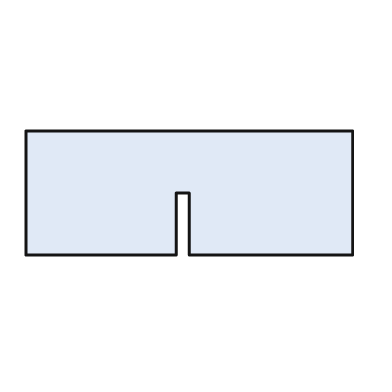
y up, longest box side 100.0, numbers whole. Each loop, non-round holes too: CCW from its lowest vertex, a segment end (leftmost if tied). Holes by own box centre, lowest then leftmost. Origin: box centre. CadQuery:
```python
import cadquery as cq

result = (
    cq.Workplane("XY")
    .moveTo(-50.0, -19.0)
    .lineTo(-4.0, -19.0)
    .lineTo(-4.0, 0.0)
    .lineTo(0.0, 0.0)
    .lineTo(0.0, -19.0)
    .lineTo(50.0, -19.0)
    .lineTo(50.0, 19.0)
    .lineTo(-50.0, 19.0)
    .close()
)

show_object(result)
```